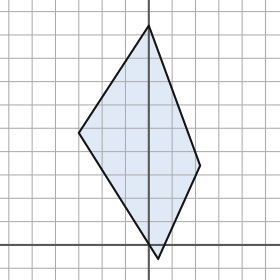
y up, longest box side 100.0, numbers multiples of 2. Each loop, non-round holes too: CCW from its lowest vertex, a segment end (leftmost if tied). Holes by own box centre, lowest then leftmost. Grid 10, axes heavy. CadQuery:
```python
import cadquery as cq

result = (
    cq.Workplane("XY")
    .moveTo(4.0, -6.0)
    .lineTo(22.0, 34.0)
    .lineTo(0.0, 94.0)
    .lineTo(-30.0, 48.0)
    .close()
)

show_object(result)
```